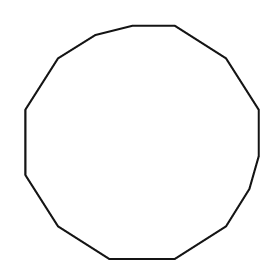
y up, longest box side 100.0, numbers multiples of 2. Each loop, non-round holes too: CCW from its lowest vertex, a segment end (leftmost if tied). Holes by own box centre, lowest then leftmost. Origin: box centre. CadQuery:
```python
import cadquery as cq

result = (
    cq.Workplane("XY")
    .moveTo(-14.0, -50.0)
    .lineTo(14.0, -50.0)
    .lineTo(36.0, -36.0)
    .lineTo(46.0, -20.0)
    .lineTo(50.0, -6.0)
    .lineTo(50.0, 14.0)
    .lineTo(36.0, 36.0)
    .lineTo(14.0, 50.0)
    .lineTo(-4.0, 50.0)
    .lineTo(-20.0, 46.0)
    .lineTo(-36.0, 36.0)
    .lineTo(-50.0, 14.0)
    .lineTo(-50.0, -14.0)
    .lineTo(-36.0, -36.0)
    .close()
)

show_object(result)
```